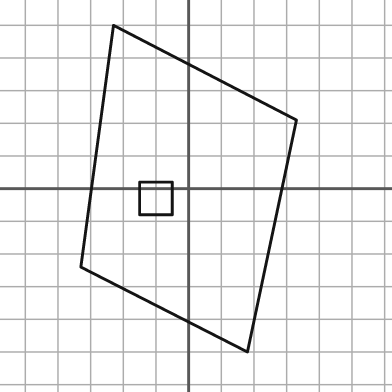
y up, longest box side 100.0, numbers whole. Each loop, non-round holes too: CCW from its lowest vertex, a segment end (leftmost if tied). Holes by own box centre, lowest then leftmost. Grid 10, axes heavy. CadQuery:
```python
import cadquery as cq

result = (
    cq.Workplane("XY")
    .moveTo(18.0, -50.0)
    .lineTo(33.0, 21.0)
    .lineTo(-23.0, 50.0)
    .lineTo(-33.0, -24.0)
    .close()
    .moveTo(-15.0, -8.0)
    .lineTo(-5.0, -8.0)
    .lineTo(-5.0, 2.0)
    .lineTo(-15.0, 2.0)
    .close()
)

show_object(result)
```